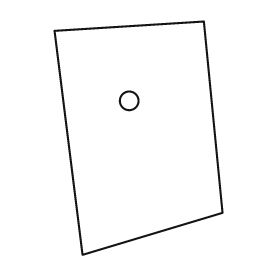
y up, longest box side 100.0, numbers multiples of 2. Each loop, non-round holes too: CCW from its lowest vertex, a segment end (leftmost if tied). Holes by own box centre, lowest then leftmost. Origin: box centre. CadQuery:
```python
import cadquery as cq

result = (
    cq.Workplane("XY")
    .moveTo(-24.0, -50.0)
    .lineTo(36.0, -32.0)
    .lineTo(28.0, 50.0)
    .lineTo(-36.0, 46.0)
    .close()
    .moveTo(-4.0, 16.0)
    .circle(4.0)
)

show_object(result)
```